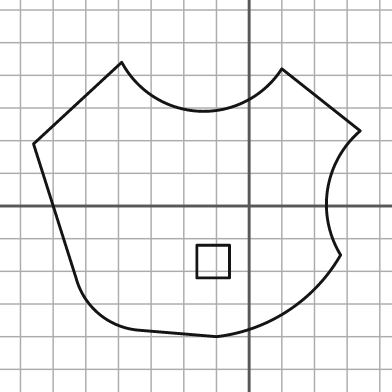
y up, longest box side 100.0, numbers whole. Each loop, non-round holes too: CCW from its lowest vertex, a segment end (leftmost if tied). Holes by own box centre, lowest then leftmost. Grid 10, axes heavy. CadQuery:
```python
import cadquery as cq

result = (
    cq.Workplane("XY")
    .moveTo(-10.0, -40.0)
    .threePointArc((12.0, -32.0), (28.0, -15.0))
    .threePointArc((24.0, 5.0), (34.0, 23.0))
    .lineTo(10.0, 42.0)
    .threePointArc((-15.0, 29.0), (-39.0, 44.0))
    .lineTo(-66.0, 19.0)
    .lineTo(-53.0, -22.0)
    .threePointArc((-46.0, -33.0), (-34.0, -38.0))
    .close()
    .moveTo(-16.0, -22.0)
    .lineTo(-6.0, -22.0)
    .lineTo(-6.0, -12.0)
    .lineTo(-16.0, -12.0)
    .close()
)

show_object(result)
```